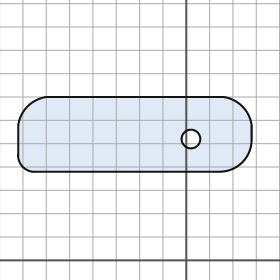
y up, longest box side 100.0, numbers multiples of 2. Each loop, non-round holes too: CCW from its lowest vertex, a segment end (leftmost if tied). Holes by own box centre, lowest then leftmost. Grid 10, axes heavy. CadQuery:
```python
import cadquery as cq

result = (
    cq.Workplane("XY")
    .moveTo(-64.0, 38.0)
    .lineTo(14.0, 38.0)
    .threePointArc((24.0, 42.0), (28.0, 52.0))
    .lineTo(28.0, 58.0)
    .threePointArc((24.0, 66.0), (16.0, 70.0))
    .lineTo(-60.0, 70.0)
    .threePointArc((-68.0, 66.0), (-72.0, 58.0))
    .lineTo(-72.0, 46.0)
    .threePointArc((-70.0, 40.0), (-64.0, 38.0))
    .close()
    .moveTo(2.0, 52.0)
    .circle(4.0)
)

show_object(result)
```